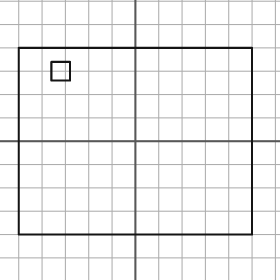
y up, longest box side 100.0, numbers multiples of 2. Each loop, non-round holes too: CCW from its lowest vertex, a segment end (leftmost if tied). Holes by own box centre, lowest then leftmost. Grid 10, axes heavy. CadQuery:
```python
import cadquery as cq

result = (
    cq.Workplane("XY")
    .moveTo(-50.0, -40.0)
    .lineTo(50.0, -40.0)
    .lineTo(50.0, 40.0)
    .lineTo(-50.0, 40.0)
    .close()
    .moveTo(-36.0, 26.0)
    .lineTo(-28.0, 26.0)
    .lineTo(-28.0, 34.0)
    .lineTo(-36.0, 34.0)
    .close()
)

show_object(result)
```